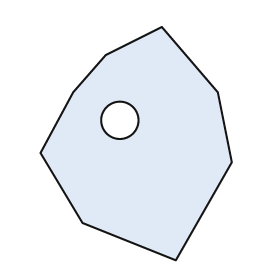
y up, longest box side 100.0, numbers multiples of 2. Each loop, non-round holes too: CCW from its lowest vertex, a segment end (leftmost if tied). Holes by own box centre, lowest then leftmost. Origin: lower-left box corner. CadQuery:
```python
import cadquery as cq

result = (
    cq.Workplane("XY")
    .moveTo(58.0, 0.0)
    .lineTo(82.0, 42.0)
    .lineTo(76.0, 72.0)
    .lineTo(52.0, 100.0)
    .lineTo(28.0, 88.0)
    .lineTo(14.0, 72.0)
    .lineTo(0.0, 46.0)
    .lineTo(18.0, 16.0)
    .close()
    .moveTo(34.0, 60.0)
    .circle(8.0)
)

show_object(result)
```